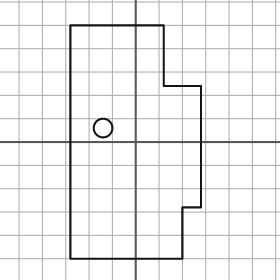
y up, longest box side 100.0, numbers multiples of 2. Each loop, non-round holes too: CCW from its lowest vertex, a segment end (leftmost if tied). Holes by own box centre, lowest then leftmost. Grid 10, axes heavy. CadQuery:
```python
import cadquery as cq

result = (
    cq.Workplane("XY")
    .moveTo(-28.0, -50.0)
    .lineTo(20.0, -50.0)
    .lineTo(20.0, -28.0)
    .lineTo(28.0, -28.0)
    .lineTo(28.0, 24.0)
    .lineTo(12.0, 24.0)
    .lineTo(12.0, 50.0)
    .lineTo(-28.0, 50.0)
    .close()
    .moveTo(-14.0, 6.0)
    .circle(4.0)
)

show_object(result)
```